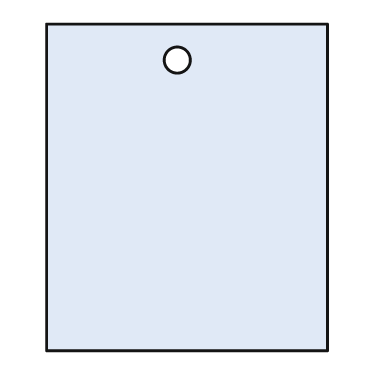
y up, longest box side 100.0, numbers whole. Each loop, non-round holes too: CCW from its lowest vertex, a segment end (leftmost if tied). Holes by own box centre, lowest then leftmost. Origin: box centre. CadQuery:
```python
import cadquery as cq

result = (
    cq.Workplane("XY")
    .moveTo(-43.0, -50.0)
    .lineTo(43.0, -50.0)
    .lineTo(43.0, 50.0)
    .lineTo(-43.0, 50.0)
    .close()
    .moveTo(-3.0, 39.0)
    .circle(4.0)
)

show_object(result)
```